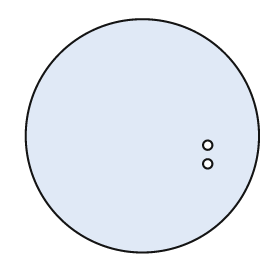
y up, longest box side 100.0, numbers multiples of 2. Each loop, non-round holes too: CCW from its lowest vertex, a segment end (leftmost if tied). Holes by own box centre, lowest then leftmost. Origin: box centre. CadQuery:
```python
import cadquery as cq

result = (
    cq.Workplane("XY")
    .moveTo(0.0, 0.0)
    .circle(50.0)
    .moveTo(28.0, -12.0)
    .circle(2.0)
    .moveTo(28.0, -4.0)
    .circle(2.0)
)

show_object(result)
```